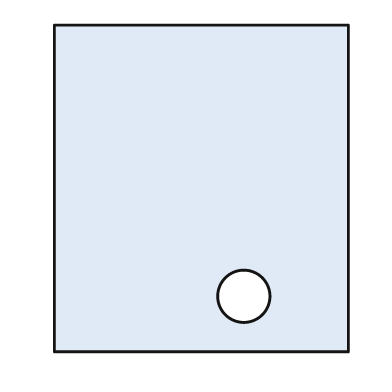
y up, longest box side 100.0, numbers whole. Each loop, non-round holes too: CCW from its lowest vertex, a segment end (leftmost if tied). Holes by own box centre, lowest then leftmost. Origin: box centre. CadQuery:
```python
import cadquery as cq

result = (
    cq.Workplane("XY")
    .moveTo(-45.0, -50.0)
    .lineTo(45.0, -50.0)
    .lineTo(45.0, 50.0)
    .lineTo(-45.0, 50.0)
    .close()
    .moveTo(13.0, -33.0)
    .circle(8.0)
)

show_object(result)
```